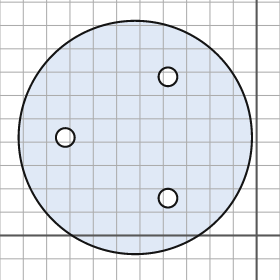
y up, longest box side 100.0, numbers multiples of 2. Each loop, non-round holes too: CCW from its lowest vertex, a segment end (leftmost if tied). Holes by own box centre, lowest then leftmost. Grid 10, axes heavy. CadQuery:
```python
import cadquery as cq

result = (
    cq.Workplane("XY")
    .moveTo(-52.0, 42.0)
    .circle(50.0)
    .moveTo(-38.0, 16.0)
    .circle(4.0)
    .moveTo(-82.0, 42.0)
    .circle(4.0)
    .moveTo(-38.0, 68.0)
    .circle(4.0)
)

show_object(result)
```